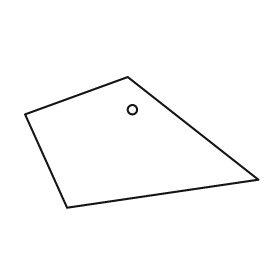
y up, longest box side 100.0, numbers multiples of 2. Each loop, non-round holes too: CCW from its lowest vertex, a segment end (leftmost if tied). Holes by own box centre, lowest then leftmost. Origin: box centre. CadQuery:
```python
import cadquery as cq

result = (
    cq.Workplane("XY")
    .moveTo(-32.0, -28.0)
    .lineTo(50.0, -16.0)
    .lineTo(-6.0, 28.0)
    .lineTo(-50.0, 12.0)
    .close()
    .moveTo(-4.0, 14.0)
    .circle(2.0)
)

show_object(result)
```